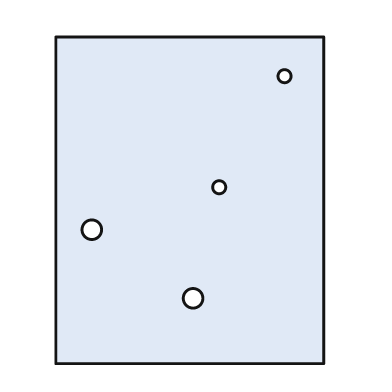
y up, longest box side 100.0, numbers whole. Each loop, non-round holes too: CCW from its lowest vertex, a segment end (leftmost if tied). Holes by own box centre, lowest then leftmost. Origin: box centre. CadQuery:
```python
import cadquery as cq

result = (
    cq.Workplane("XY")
    .moveTo(-41.0, -50.0)
    .lineTo(41.0, -50.0)
    .lineTo(41.0, 50.0)
    .lineTo(-41.0, 50.0)
    .close()
    .moveTo(1.0, -30.0)
    .circle(3.0)
    .moveTo(-30.0, -9.0)
    .circle(3.0)
    .moveTo(9.0, 4.0)
    .circle(2.0)
    .moveTo(29.0, 38.0)
    .circle(2.0)
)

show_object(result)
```